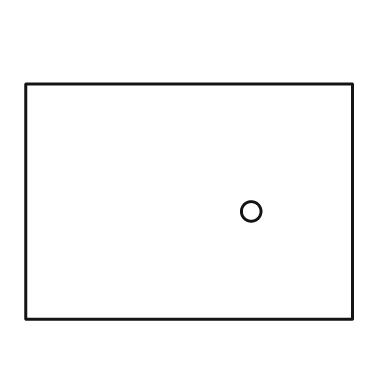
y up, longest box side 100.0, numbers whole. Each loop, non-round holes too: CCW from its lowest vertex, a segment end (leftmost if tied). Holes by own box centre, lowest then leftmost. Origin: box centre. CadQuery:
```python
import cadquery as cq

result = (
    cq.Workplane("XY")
    .moveTo(-50.0, -36.0)
    .lineTo(50.0, -36.0)
    .lineTo(50.0, 36.0)
    .lineTo(-50.0, 36.0)
    .close()
    .moveTo(19.0, -3.0)
    .circle(3.0)
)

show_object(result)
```